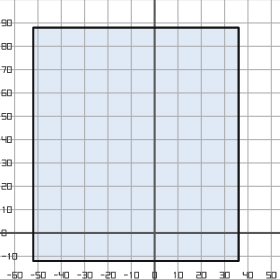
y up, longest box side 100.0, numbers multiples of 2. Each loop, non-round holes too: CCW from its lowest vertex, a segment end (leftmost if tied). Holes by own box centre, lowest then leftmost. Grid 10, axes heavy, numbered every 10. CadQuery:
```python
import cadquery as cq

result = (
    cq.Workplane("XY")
    .moveTo(-52.0, -12.0)
    .lineTo(36.0, -12.0)
    .lineTo(36.0, 88.0)
    .lineTo(-52.0, 88.0)
    .close()
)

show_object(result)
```